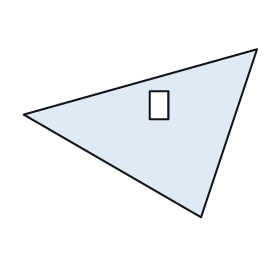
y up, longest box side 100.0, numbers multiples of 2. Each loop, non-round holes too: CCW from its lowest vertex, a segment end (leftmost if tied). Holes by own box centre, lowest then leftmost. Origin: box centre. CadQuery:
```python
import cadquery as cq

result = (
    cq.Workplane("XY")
    .moveTo(26.0, -36.0)
    .lineTo(50.0, 36.0)
    .lineTo(-50.0, 8.0)
    .close()
    .moveTo(4.0, 6.0)
    .lineTo(12.0, 6.0)
    .lineTo(12.0, 18.0)
    .lineTo(4.0, 18.0)
    .close()
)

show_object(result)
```